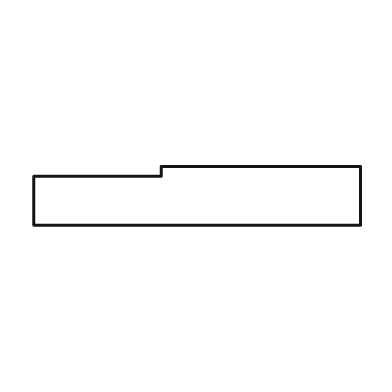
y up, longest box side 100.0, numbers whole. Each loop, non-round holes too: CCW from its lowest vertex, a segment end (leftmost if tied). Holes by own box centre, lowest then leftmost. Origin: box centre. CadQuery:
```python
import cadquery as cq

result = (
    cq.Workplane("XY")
    .moveTo(-50.0, -9.0)
    .lineTo(50.0, -9.0)
    .lineTo(50.0, 9.0)
    .lineTo(-11.0, 9.0)
    .lineTo(-11.0, 6.0)
    .lineTo(-50.0, 6.0)
    .close()
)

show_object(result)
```